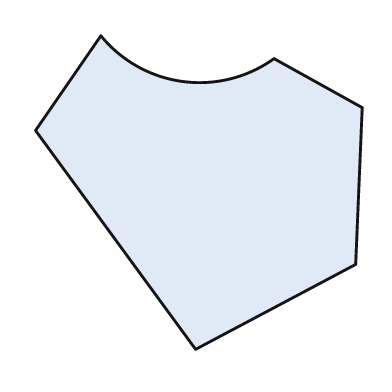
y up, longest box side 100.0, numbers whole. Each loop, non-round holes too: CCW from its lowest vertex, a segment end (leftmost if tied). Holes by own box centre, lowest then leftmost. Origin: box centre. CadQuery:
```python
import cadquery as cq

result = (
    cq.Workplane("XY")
    .moveTo(-1.0, -48.0)
    .lineTo(48.0, -22.0)
    .lineTo(50.0, 26.0)
    .lineTo(23.0, 41.0)
    .threePointArc((-5.0, 34.0), (-30.0, 48.0))
    .lineTo(-50.0, 19.0)
    .close()
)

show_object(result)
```